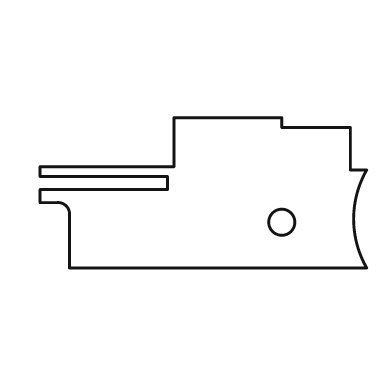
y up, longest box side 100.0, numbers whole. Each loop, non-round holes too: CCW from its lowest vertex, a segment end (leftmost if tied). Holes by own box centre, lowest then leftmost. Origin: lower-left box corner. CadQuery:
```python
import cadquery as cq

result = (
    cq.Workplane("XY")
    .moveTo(9.0, 0.0)
    .lineTo(100.0, 0.0)
    .threePointArc((96.0, 15.0), (100.0, 30.0))
    .lineTo(95.0, 30.0)
    .lineTo(95.0, 43.0)
    .lineTo(74.0, 43.0)
    .lineTo(74.0, 46.0)
    .lineTo(41.0, 46.0)
    .lineTo(41.0, 31.0)
    .lineTo(0.0, 31.0)
    .lineTo(0.0, 28.0)
    .lineTo(39.0, 28.0)
    .lineTo(39.0, 24.0)
    .lineTo(0.0, 24.0)
    .lineTo(0.0, 20.0)
    .lineTo(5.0, 20.0)
    .threePointArc((8.0, 19.0), (9.0, 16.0))
    .close()
    .moveTo(74.0, 14.0)
    .circle(4.0)
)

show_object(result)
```